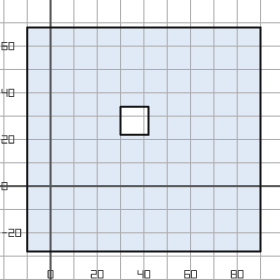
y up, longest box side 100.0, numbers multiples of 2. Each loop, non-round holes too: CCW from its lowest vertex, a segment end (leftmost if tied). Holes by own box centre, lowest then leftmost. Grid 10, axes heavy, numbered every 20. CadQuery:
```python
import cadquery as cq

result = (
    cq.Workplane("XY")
    .moveTo(-10.0, -28.0)
    .lineTo(90.0, -28.0)
    .lineTo(90.0, 68.0)
    .lineTo(-10.0, 68.0)
    .close()
    .moveTo(30.0, 22.0)
    .lineTo(42.0, 22.0)
    .lineTo(42.0, 34.0)
    .lineTo(30.0, 34.0)
    .close()
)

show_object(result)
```